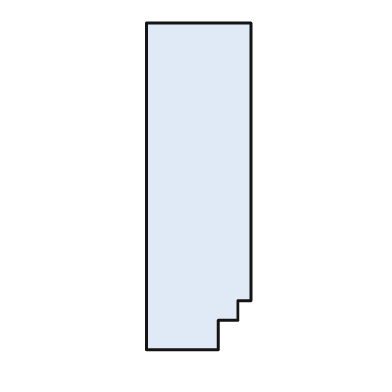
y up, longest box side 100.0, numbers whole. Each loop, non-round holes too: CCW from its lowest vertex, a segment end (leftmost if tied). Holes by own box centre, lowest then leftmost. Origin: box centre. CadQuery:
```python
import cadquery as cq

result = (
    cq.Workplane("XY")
    .moveTo(-16.0, -50.0)
    .lineTo(6.0, -50.0)
    .lineTo(6.0, -41.0)
    .lineTo(12.0, -41.0)
    .lineTo(12.0, -35.0)
    .lineTo(16.0, -35.0)
    .lineTo(16.0, 50.0)
    .lineTo(-16.0, 50.0)
    .close()
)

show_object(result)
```